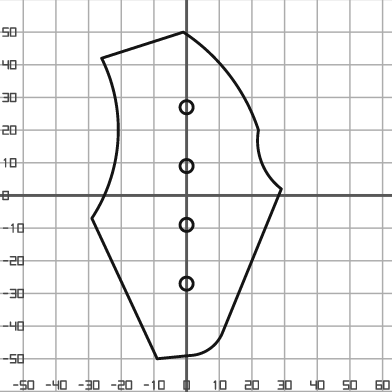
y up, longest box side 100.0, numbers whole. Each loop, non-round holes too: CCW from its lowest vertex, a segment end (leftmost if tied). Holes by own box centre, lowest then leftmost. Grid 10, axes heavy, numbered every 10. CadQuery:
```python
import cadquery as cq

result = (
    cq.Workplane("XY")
    .moveTo(-9.0, -50.0)
    .lineTo(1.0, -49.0)
    .threePointArc((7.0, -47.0), (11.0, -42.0))
    .lineTo(29.0, 2.0)
    .threePointArc((23.0, 10.0), (22.0, 20.0))
    .threePointArc((13.0, 37.0), (-1.0, 50.0))
    .lineTo(-26.0, 42.0)
    .threePointArc((-21.0, 17.0), (-29.0, -7.0))
    .close()
    .moveTo(0.0, -27.0)
    .circle(2.0)
    .moveTo(0.0, -9.0)
    .circle(2.0)
    .moveTo(0.0, 9.0)
    .circle(2.0)
    .moveTo(0.0, 27.0)
    .circle(2.0)
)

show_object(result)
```